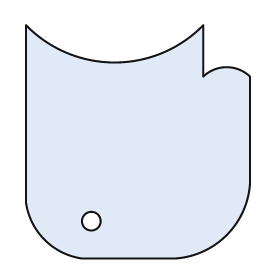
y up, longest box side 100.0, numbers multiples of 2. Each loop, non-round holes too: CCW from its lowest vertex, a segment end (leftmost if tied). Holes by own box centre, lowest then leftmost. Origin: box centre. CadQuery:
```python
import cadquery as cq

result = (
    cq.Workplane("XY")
    .moveTo(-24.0, -50.0)
    .lineTo(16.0, -50.0)
    .threePointArc((38.0, -40.0), (48.0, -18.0))
    .lineTo(48.0, 28.0)
    .threePointArc((38.0, 32.0), (28.0, 28.0))
    .lineTo(28.0, 50.0)
    .threePointArc((-10.0, 34.0), (-48.0, 50.0))
    .lineTo(-48.0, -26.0)
    .threePointArc((-40.0, -42.0), (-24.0, -50.0))
    .close()
    .moveTo(-20.0, -34.0)
    .circle(4.0)
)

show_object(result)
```